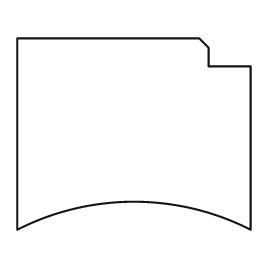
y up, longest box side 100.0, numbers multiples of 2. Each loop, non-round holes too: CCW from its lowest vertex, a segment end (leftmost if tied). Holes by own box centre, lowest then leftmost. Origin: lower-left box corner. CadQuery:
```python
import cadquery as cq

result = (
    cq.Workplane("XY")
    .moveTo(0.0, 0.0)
    .threePointArc((50.0, 12.0), (100.0, 0.0))
    .lineTo(100.0, 70.0)
    .lineTo(82.0, 70.0)
    .lineTo(82.0, 78.0)
    .lineTo(78.0, 82.0)
    .lineTo(0.0, 82.0)
    .close()
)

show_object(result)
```